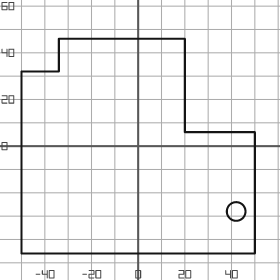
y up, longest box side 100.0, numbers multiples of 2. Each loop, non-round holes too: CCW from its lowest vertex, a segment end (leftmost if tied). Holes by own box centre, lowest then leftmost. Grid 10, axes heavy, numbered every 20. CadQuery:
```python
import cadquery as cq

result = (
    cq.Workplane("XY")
    .moveTo(-50.0, -46.0)
    .lineTo(50.0, -46.0)
    .lineTo(50.0, 6.0)
    .lineTo(20.0, 6.0)
    .lineTo(20.0, 46.0)
    .lineTo(-34.0, 46.0)
    .lineTo(-34.0, 32.0)
    .lineTo(-50.0, 32.0)
    .close()
    .moveTo(42.0, -28.0)
    .circle(4.0)
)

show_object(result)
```